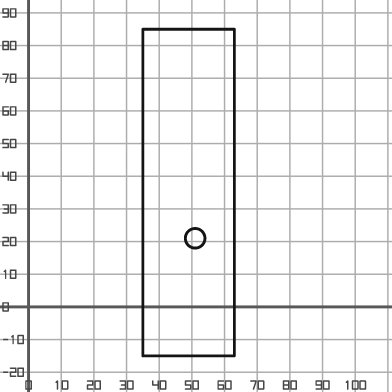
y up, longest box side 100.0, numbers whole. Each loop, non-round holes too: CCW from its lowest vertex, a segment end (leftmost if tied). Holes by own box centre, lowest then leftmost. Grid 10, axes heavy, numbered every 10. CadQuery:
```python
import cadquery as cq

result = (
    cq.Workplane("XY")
    .moveTo(35.0, -15.0)
    .lineTo(63.0, -15.0)
    .lineTo(63.0, 85.0)
    .lineTo(35.0, 85.0)
    .close()
    .moveTo(51.0, 21.0)
    .circle(3.0)
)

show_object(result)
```